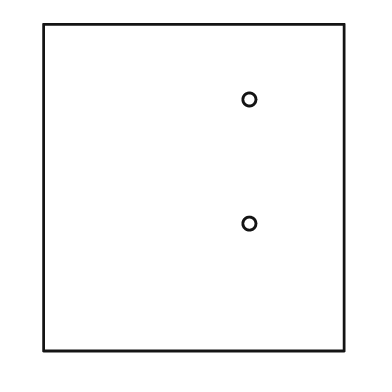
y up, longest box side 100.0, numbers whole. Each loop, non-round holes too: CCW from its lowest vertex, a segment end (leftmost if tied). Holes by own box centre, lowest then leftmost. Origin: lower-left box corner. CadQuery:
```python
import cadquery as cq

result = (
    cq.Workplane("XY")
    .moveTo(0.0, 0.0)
    .lineTo(92.0, 0.0)
    .lineTo(92.0, 100.0)
    .lineTo(0.0, 100.0)
    .close()
    .moveTo(63.0, 39.0)
    .circle(2.0)
    .moveTo(63.0, 77.0)
    .circle(2.0)
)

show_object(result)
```